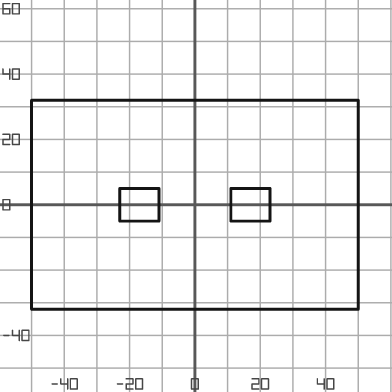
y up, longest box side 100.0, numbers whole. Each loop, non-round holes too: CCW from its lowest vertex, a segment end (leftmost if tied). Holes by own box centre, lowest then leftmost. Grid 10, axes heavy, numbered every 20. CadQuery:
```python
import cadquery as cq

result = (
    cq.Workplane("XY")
    .moveTo(-50.0, -32.0)
    .lineTo(50.0, -32.0)
    .lineTo(50.0, 32.0)
    .lineTo(-50.0, 32.0)
    .close()
    .moveTo(-23.0, -5.0)
    .lineTo(-11.0, -5.0)
    .lineTo(-11.0, 5.0)
    .lineTo(-23.0, 5.0)
    .close()
    .moveTo(11.0, -5.0)
    .lineTo(23.0, -5.0)
    .lineTo(23.0, 5.0)
    .lineTo(11.0, 5.0)
    .close()
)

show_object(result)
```